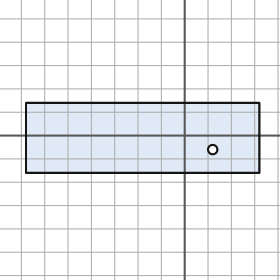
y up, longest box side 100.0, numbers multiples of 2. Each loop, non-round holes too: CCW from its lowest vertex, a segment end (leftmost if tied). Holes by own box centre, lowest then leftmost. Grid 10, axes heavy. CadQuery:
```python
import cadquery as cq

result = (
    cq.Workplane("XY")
    .moveTo(-68.0, -16.0)
    .lineTo(32.0, -16.0)
    .lineTo(32.0, 14.0)
    .lineTo(-68.0, 14.0)
    .close()
    .moveTo(12.0, -6.0)
    .circle(2.0)
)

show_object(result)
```